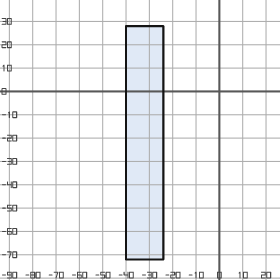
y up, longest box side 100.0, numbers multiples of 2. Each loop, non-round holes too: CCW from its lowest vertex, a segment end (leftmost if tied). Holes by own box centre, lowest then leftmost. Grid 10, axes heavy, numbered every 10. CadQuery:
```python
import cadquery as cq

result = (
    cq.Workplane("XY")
    .moveTo(-40.0, -72.0)
    .lineTo(-24.0, -72.0)
    .lineTo(-24.0, 28.0)
    .lineTo(-40.0, 28.0)
    .close()
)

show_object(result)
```